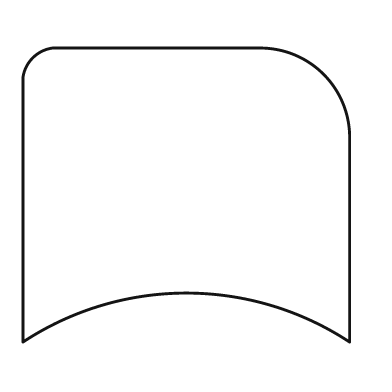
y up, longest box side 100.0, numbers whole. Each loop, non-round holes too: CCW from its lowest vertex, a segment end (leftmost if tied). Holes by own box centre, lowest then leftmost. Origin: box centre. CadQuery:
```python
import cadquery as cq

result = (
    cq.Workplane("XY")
    .moveTo(-50.0, -45.0)
    .threePointArc((0.0, -30.0), (50.0, -45.0))
    .lineTo(50.0, 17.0)
    .threePointArc((42.0, 37.0), (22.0, 45.0))
    .lineTo(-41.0, 45.0)
    .threePointArc((-47.0, 42.0), (-50.0, 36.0))
    .close()
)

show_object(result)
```